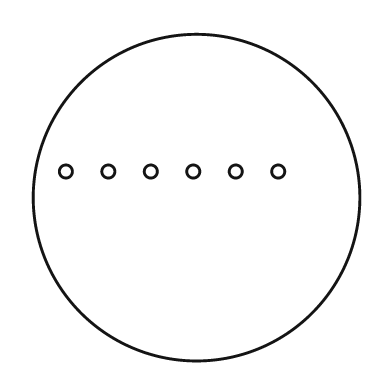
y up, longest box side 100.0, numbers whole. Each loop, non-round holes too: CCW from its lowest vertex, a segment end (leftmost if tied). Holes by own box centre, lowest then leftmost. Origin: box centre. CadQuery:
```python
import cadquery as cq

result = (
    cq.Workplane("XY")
    .moveTo(0.0, 0.0)
    .circle(50.0)
    .moveTo(-40.0, 8.0)
    .circle(2.0)
    .moveTo(-27.0, 8.0)
    .circle(2.0)
    .moveTo(-14.0, 8.0)
    .circle(2.0)
    .moveTo(-1.0, 8.0)
    .circle(2.0)
    .moveTo(12.0, 8.0)
    .circle(2.0)
    .moveTo(25.0, 8.0)
    .circle(2.0)
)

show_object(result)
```